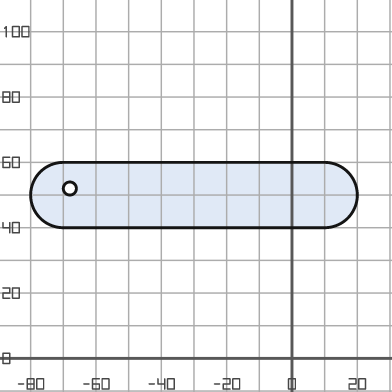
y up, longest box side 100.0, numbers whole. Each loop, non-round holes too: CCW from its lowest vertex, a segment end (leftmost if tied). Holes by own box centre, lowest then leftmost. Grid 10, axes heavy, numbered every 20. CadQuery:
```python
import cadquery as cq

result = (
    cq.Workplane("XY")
    .moveTo(-70.0, 40.0)
    .lineTo(10.0, 40.0)
    .threePointArc((20.0, 50.0), (10.0, 60.0))
    .lineTo(-70.0, 60.0)
    .threePointArc((-80.0, 50.0), (-70.0, 40.0))
    .close()
    .moveTo(-68.0, 52.0)
    .circle(2.0)
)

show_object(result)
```